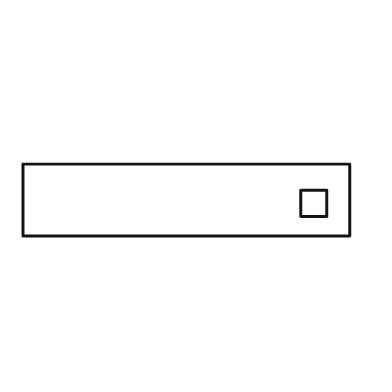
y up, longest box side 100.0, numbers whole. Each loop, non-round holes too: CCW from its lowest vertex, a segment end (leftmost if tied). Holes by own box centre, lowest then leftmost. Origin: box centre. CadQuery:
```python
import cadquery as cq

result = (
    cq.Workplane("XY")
    .moveTo(-50.0, -11.0)
    .lineTo(50.0, -11.0)
    .lineTo(50.0, 11.0)
    .lineTo(-50.0, 11.0)
    .close()
    .moveTo(35.0, -5.0)
    .lineTo(43.0, -5.0)
    .lineTo(43.0, 3.0)
    .lineTo(35.0, 3.0)
    .close()
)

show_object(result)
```